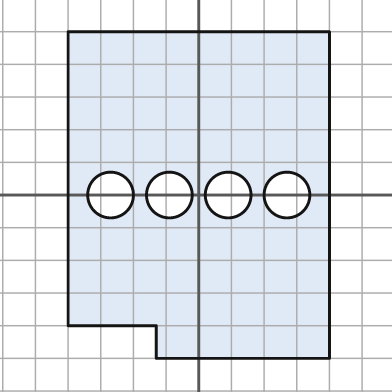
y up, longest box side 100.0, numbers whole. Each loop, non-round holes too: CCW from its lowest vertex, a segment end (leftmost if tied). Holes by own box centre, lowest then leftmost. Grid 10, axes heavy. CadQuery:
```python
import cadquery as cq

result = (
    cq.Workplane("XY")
    .moveTo(-13.0, -50.0)
    .lineTo(40.0, -50.0)
    .lineTo(40.0, 50.0)
    .lineTo(-40.0, 50.0)
    .lineTo(-40.0, -40.0)
    .lineTo(-13.0, -40.0)
    .close()
    .moveTo(-27.0, 0.0)
    .circle(7.0)
    .moveTo(-9.0, 0.0)
    .circle(7.0)
    .moveTo(9.0, 0.0)
    .circle(7.0)
    .moveTo(27.0, 0.0)
    .circle(7.0)
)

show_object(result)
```